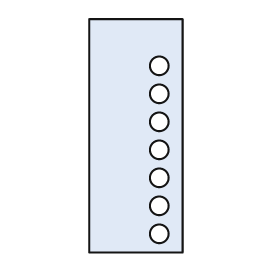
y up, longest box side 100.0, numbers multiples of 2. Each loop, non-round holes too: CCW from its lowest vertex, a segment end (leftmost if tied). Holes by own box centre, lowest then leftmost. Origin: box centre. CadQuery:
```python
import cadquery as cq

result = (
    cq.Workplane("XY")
    .moveTo(-20.0, -50.0)
    .lineTo(20.0, -50.0)
    .lineTo(20.0, 50.0)
    .lineTo(-20.0, 50.0)
    .close()
    .moveTo(10.0, -42.0)
    .circle(4.0)
    .moveTo(10.0, -30.0)
    .circle(4.0)
    .moveTo(10.0, -18.0)
    .circle(4.0)
    .moveTo(10.0, -6.0)
    .circle(4.0)
    .moveTo(10.0, 6.0)
    .circle(4.0)
    .moveTo(10.0, 18.0)
    .circle(4.0)
    .moveTo(10.0, 30.0)
    .circle(4.0)
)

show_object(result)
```